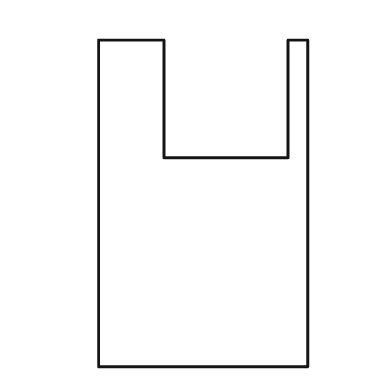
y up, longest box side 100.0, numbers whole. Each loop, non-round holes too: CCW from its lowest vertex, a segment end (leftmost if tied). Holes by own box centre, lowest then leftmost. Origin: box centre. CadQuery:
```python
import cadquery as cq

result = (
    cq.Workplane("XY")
    .moveTo(-32.0, -50.0)
    .lineTo(32.0, -50.0)
    .lineTo(32.0, 50.0)
    .lineTo(26.0, 50.0)
    .lineTo(26.0, 14.0)
    .lineTo(-12.0, 14.0)
    .lineTo(-12.0, 50.0)
    .lineTo(-32.0, 50.0)
    .close()
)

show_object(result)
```